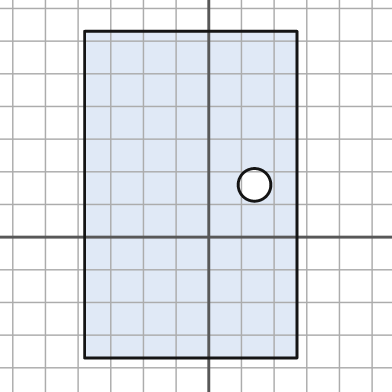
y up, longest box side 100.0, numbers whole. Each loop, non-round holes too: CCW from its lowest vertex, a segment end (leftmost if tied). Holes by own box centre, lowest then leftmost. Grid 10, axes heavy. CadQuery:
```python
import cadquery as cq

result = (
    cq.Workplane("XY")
    .moveTo(-38.0, -37.0)
    .lineTo(27.0, -37.0)
    .lineTo(27.0, 63.0)
    .lineTo(-38.0, 63.0)
    .close()
    .moveTo(14.0, 16.0)
    .circle(5.0)
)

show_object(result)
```